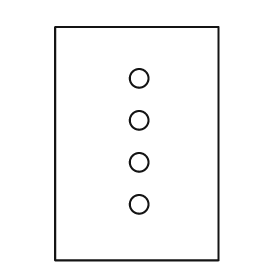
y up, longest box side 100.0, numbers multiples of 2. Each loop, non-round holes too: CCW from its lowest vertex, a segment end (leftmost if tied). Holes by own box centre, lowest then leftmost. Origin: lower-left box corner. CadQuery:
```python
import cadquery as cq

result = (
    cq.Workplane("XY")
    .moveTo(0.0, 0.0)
    .lineTo(70.0, 0.0)
    .lineTo(70.0, 100.0)
    .lineTo(0.0, 100.0)
    .close()
    .moveTo(36.0, 24.0)
    .circle(4.0)
    .moveTo(36.0, 42.0)
    .circle(4.0)
    .moveTo(36.0, 60.0)
    .circle(4.0)
    .moveTo(36.0, 78.0)
    .circle(4.0)
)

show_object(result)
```